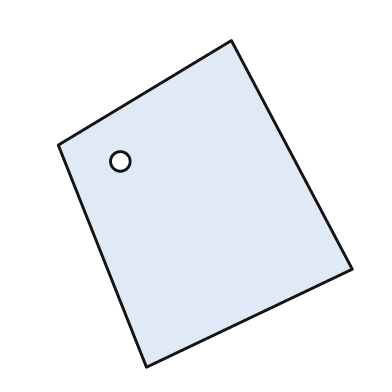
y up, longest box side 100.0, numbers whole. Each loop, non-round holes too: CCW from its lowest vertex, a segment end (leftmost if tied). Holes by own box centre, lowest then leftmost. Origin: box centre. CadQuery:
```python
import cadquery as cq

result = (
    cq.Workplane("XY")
    .moveTo(-18.0, -50.0)
    .lineTo(45.0, -20.0)
    .lineTo(8.0, 50.0)
    .lineTo(-45.0, 18.0)
    .close()
    .moveTo(-26.0, 13.0)
    .circle(3.0)
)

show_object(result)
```